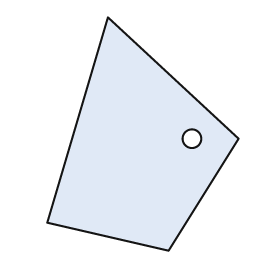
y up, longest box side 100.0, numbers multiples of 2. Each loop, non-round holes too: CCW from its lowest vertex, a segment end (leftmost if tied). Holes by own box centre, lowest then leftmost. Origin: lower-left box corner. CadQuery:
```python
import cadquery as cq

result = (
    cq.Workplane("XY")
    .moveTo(52.0, 0.0)
    .lineTo(82.0, 48.0)
    .lineTo(26.0, 100.0)
    .lineTo(0.0, 12.0)
    .close()
    .moveTo(62.0, 48.0)
    .circle(4.0)
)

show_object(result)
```